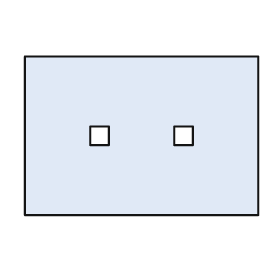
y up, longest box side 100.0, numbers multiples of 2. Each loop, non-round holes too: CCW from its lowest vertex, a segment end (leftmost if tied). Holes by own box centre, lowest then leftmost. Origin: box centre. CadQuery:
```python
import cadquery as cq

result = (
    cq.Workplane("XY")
    .moveTo(-50.0, -34.0)
    .lineTo(50.0, -34.0)
    .lineTo(50.0, 34.0)
    .lineTo(-50.0, 34.0)
    .close()
    .moveTo(-22.0, -4.0)
    .lineTo(-14.0, -4.0)
    .lineTo(-14.0, 4.0)
    .lineTo(-22.0, 4.0)
    .close()
    .moveTo(14.0, -4.0)
    .lineTo(22.0, -4.0)
    .lineTo(22.0, 4.0)
    .lineTo(14.0, 4.0)
    .close()
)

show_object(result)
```